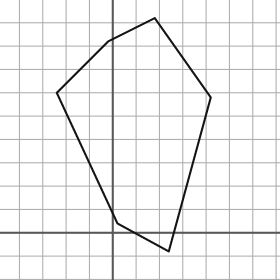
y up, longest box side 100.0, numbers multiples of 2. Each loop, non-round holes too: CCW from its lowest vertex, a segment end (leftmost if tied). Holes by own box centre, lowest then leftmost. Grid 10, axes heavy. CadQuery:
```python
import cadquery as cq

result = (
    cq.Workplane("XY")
    .moveTo(24.0, -8.0)
    .lineTo(42.0, 58.0)
    .lineTo(18.0, 92.0)
    .lineTo(-2.0, 82.0)
    .lineTo(-24.0, 60.0)
    .lineTo(2.0, 4.0)
    .close()
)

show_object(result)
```